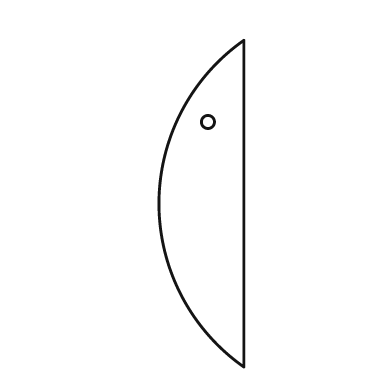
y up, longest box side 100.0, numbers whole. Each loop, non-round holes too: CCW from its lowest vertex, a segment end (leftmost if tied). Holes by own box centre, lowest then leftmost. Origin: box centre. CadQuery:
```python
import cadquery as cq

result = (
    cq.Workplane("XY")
    .moveTo(13.0, -50.0)
    .lineTo(13.0, 50.0)
    .threePointArc((-13.0, 0.0), (13.0, -50.0))
    .close()
    .moveTo(2.0, 25.0)
    .circle(2.0)
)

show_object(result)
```